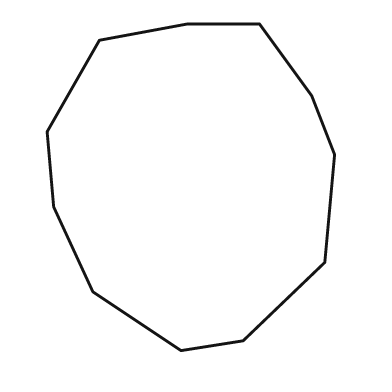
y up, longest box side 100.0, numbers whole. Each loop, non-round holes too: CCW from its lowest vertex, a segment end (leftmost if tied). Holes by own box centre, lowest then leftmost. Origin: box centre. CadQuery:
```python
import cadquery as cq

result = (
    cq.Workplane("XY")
    .moveTo(-3.0, -50.0)
    .lineTo(16.0, -47.0)
    .lineTo(41.0, -23.0)
    .lineTo(44.0, 10.0)
    .lineTo(37.0, 28.0)
    .lineTo(21.0, 50.0)
    .lineTo(-1.0, 50.0)
    .lineTo(-28.0, 45.0)
    .lineTo(-44.0, 17.0)
    .lineTo(-42.0, -6.0)
    .lineTo(-30.0, -32.0)
    .close()
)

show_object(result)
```